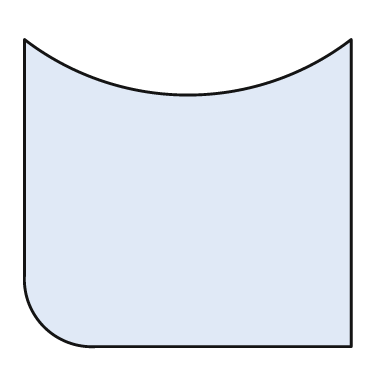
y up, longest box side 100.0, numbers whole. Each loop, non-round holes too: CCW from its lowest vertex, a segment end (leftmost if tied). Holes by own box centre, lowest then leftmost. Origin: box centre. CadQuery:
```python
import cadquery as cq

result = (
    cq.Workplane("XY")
    .moveTo(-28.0, -47.0)
    .lineTo(50.0, -47.0)
    .lineTo(50.0, 47.0)
    .threePointArc((0.0, 30.0), (-50.0, 47.0))
    .lineTo(-50.0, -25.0)
    .threePointArc((-44.0, -41.0), (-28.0, -47.0))
    .close()
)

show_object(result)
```